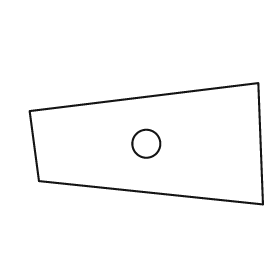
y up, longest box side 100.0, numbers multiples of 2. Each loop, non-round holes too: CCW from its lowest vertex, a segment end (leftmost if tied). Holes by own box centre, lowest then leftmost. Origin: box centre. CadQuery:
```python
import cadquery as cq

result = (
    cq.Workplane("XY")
    .moveTo(50.0, -26.0)
    .lineTo(48.0, 26.0)
    .lineTo(-50.0, 14.0)
    .lineTo(-46.0, -16.0)
    .close()
    .moveTo(0.0, 0.0)
    .circle(6.0)
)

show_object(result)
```